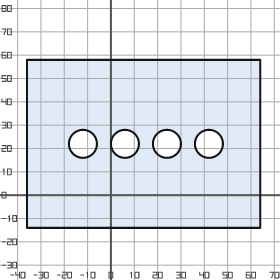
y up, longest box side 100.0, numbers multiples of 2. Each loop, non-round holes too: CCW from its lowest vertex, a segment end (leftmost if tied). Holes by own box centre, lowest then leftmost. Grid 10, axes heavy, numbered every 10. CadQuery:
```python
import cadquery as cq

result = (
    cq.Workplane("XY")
    .moveTo(-36.0, -14.0)
    .lineTo(64.0, -14.0)
    .lineTo(64.0, 58.0)
    .lineTo(-36.0, 58.0)
    .close()
    .moveTo(-12.0, 22.0)
    .circle(6.0)
    .moveTo(6.0, 22.0)
    .circle(6.0)
    .moveTo(24.0, 22.0)
    .circle(6.0)
    .moveTo(42.0, 22.0)
    .circle(6.0)
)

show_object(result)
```